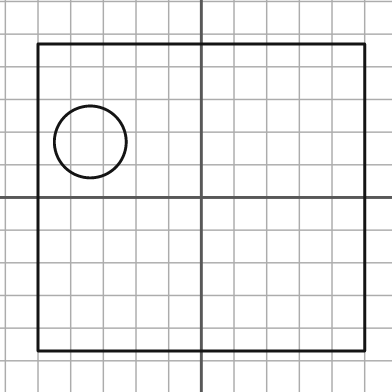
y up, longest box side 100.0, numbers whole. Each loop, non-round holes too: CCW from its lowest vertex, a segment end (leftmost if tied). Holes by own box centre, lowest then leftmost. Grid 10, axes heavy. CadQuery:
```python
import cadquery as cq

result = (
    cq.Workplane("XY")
    .moveTo(-50.0, -47.0)
    .lineTo(50.0, -47.0)
    .lineTo(50.0, 47.0)
    .lineTo(-50.0, 47.0)
    .close()
    .moveTo(-34.0, 17.0)
    .circle(11.0)
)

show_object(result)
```